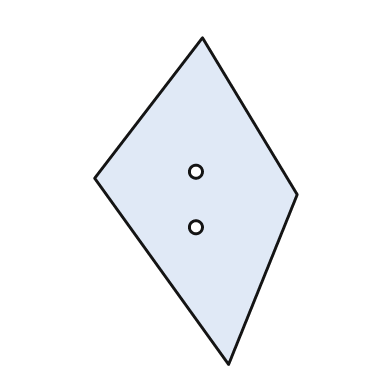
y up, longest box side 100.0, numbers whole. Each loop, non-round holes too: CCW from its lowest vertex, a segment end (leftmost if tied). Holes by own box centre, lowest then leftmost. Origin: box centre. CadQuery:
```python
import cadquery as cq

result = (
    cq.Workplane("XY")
    .moveTo(10.0, -50.0)
    .lineTo(31.0, 2.0)
    .lineTo(2.0, 50.0)
    .lineTo(-31.0, 7.0)
    .close()
    .moveTo(0.0, -8.0)
    .circle(2.0)
    .moveTo(0.0, 9.0)
    .circle(2.0)
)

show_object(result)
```